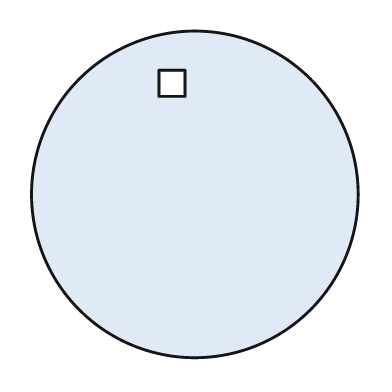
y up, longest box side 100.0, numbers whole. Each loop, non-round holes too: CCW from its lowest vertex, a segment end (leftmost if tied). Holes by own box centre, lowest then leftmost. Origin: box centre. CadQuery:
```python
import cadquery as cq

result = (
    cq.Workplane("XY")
    .moveTo(0.0, 0.0)
    .circle(50.0)
    .moveTo(-11.0, 30.0)
    .lineTo(-3.0, 30.0)
    .lineTo(-3.0, 38.0)
    .lineTo(-11.0, 38.0)
    .close()
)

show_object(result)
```